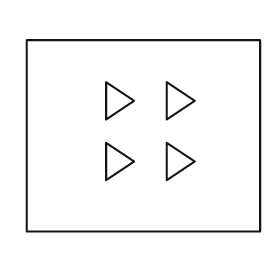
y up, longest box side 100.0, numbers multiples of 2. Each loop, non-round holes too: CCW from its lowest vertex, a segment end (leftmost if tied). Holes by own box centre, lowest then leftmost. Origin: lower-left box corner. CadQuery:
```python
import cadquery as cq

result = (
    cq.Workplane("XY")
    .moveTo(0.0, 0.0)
    .lineTo(100.0, 0.0)
    .lineTo(100.0, 82.0)
    .lineTo(0.0, 82.0)
    .close()
    .moveTo(34.0, 22.0)
    .lineTo(46.0, 30.0)
    .lineTo(34.0, 38.0)
    .close()
    .moveTo(60.0, 22.0)
    .lineTo(72.0, 30.0)
    .lineTo(60.0, 38.0)
    .close()
    .moveTo(34.0, 48.0)
    .lineTo(46.0, 56.0)
    .lineTo(34.0, 64.0)
    .close()
    .moveTo(60.0, 48.0)
    .lineTo(72.0, 56.0)
    .lineTo(60.0, 64.0)
    .close()
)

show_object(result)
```